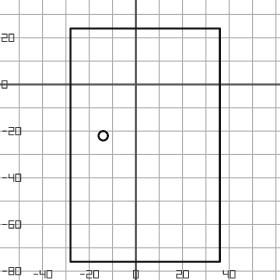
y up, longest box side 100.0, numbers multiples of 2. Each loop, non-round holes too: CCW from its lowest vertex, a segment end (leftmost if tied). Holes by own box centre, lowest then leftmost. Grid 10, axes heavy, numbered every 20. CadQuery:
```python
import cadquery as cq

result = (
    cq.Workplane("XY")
    .moveTo(-28.0, -76.0)
    .lineTo(36.0, -76.0)
    .lineTo(36.0, 24.0)
    .lineTo(-28.0, 24.0)
    .close()
    .moveTo(-14.0, -22.0)
    .circle(2.0)
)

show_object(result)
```